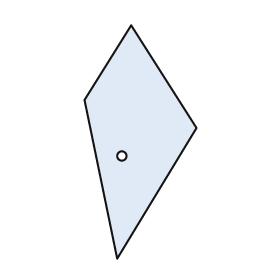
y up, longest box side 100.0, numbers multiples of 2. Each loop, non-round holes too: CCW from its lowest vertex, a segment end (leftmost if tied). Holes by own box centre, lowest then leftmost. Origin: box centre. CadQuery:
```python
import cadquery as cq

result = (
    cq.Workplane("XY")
    .moveTo(-10.0, -50.0)
    .lineTo(24.0, 6.0)
    .lineTo(-4.0, 50.0)
    .lineTo(-24.0, 18.0)
    .close()
    .moveTo(-8.0, -6.0)
    .circle(2.0)
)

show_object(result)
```